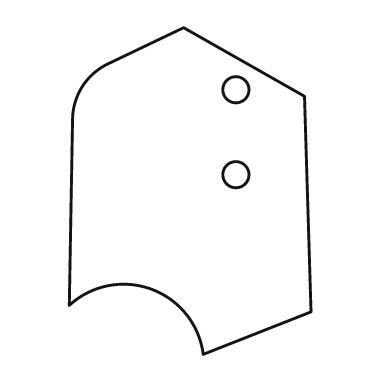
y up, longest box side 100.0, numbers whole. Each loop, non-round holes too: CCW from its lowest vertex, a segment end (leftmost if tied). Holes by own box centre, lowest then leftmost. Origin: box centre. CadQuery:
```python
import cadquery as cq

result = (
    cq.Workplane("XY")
    .moveTo(4.0, -50.0)
    .lineTo(37.0, -37.0)
    .lineTo(35.0, 29.0)
    .lineTo(-2.0, 50.0)
    .lineTo(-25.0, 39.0)
    .threePointArc((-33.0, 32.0), (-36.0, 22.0))
    .lineTo(-37.0, -35.0)
    .threePointArc((-12.0, -30.0), (4.0, -50.0))
    .close()
    .moveTo(14.0, 5.0)
    .circle(4.0)
    .moveTo(14.0, 31.0)
    .circle(4.0)
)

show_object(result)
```